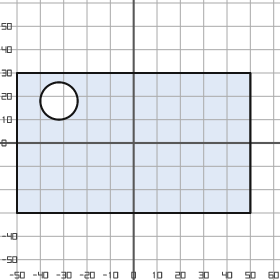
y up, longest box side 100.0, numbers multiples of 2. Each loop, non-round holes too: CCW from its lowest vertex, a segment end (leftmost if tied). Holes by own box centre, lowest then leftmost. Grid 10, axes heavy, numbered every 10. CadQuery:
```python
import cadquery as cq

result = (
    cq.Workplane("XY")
    .moveTo(-50.0, -30.0)
    .lineTo(50.0, -30.0)
    .lineTo(50.0, 30.0)
    .lineTo(-50.0, 30.0)
    .close()
    .moveTo(-32.0, 18.0)
    .circle(8.0)
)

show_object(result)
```